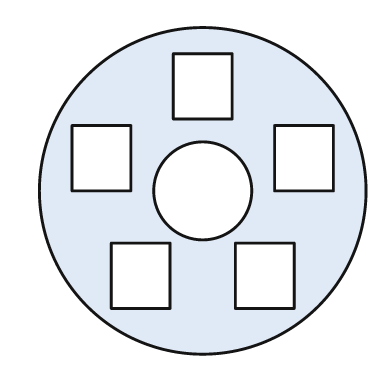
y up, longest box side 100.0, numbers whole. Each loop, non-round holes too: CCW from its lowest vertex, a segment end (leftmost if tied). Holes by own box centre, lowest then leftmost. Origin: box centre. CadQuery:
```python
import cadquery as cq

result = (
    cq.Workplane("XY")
    .moveTo(0.0, 0.0)
    .circle(50.0)
    .moveTo(-28.0, -36.0)
    .lineTo(-10.0, -36.0)
    .lineTo(-10.0, -16.0)
    .lineTo(-28.0, -16.0)
    .close()
    .moveTo(10.0, -36.0)
    .lineTo(28.0, -36.0)
    .lineTo(28.0, -16.0)
    .lineTo(10.0, -16.0)
    .close()
    .moveTo(0.0, 0.0)
    .circle(15.0)
    .moveTo(-40.0, 0.0)
    .lineTo(-22.0, 0.0)
    .lineTo(-22.0, 20.0)
    .lineTo(-40.0, 20.0)
    .close()
    .moveTo(22.0, 0.0)
    .lineTo(40.0, 0.0)
    .lineTo(40.0, 20.0)
    .lineTo(22.0, 20.0)
    .close()
    .moveTo(-9.0, 22.0)
    .lineTo(9.0, 22.0)
    .lineTo(9.0, 42.0)
    .lineTo(-9.0, 42.0)
    .close()
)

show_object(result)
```